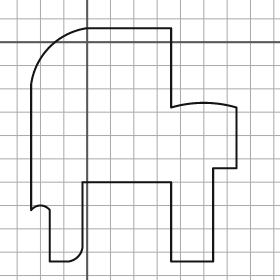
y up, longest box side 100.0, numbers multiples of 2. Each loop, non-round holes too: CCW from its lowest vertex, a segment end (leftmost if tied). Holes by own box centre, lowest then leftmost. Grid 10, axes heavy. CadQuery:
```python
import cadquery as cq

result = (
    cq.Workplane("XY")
    .moveTo(-16.0, -94.0)
    .lineTo(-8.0, -94.0)
    .threePointArc((-4.0, -92.0), (-2.0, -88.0))
    .lineTo(-2.0, -60.0)
    .lineTo(36.0, -60.0)
    .lineTo(36.0, -94.0)
    .lineTo(54.0, -94.0)
    .lineTo(54.0, -54.0)
    .lineTo(64.0, -54.0)
    .lineTo(64.0, -28.0)
    .threePointArc((50.0, -26.0), (36.0, -28.0))
    .lineTo(36.0, 6.0)
    .lineTo(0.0, 6.0)
    .threePointArc((-16.0, -2.0), (-24.0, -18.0))
    .lineTo(-24.0, -72.0)
    .threePointArc((-20.0, -70.0), (-16.0, -72.0))
    .close()
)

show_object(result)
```